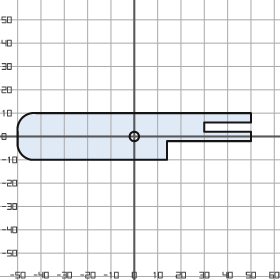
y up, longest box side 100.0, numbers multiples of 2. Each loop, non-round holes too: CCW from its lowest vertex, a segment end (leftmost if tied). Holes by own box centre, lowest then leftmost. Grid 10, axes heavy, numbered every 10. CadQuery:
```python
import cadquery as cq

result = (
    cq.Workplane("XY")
    .moveTo(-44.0, -10.0)
    .lineTo(14.0, -10.0)
    .lineTo(14.0, -2.0)
    .lineTo(50.0, -2.0)
    .lineTo(50.0, 2.0)
    .lineTo(30.0, 2.0)
    .lineTo(30.0, 6.0)
    .lineTo(50.0, 6.0)
    .lineTo(50.0, 10.0)
    .lineTo(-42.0, 10.0)
    .threePointArc((-48.0, 8.0), (-50.0, 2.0))
    .lineTo(-50.0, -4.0)
    .threePointArc((-48.0, -8.0), (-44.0, -10.0))
    .close()
    .moveTo(0.0, 0.0)
    .circle(2.0)
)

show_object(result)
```